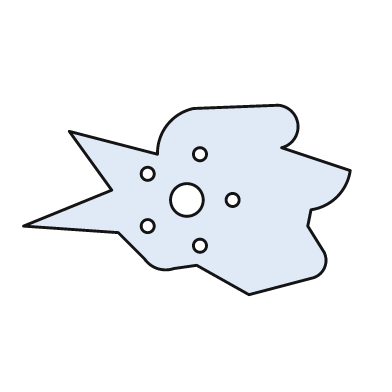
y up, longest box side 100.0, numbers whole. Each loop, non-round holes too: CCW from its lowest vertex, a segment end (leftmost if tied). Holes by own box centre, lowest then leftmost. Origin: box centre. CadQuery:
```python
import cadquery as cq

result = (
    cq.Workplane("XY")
    .moveTo(19.0, -29.0)
    .lineTo(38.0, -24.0)
    .threePointArc((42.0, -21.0), (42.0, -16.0))
    .lineTo(37.0, -8.0)
    .lineTo(38.0, -3.0)
    .threePointArc((46.0, 1.0), (50.0, 9.0))
    .lineTo(29.0, 16.0)
    .threePointArc((34.0, 23.0), (28.0, 29.0))
    .lineTo(2.0, 28.0)
    .threePointArc((-6.0, 23.0), (-9.0, 14.0))
    .lineTo(-36.0, 21.0)
    .lineTo(-23.0, 3.0)
    .lineTo(-50.0, -8.0)
    .lineTo(-21.0, -10.0)
    .lineTo(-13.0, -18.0)
    .threePointArc((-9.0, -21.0), (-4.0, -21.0))
    .lineTo(3.0, -20.0)
    .close()
    .moveTo(4.0, -14.0)
    .circle(2.0)
    .moveTo(-12.0, -8.0)
    .circle(2.0)
    .moveTo(0.0, 0.0)
    .circle(5.0)
    .moveTo(14.0, 0.0)
    .circle(2.0)
    .moveTo(-12.0, 8.0)
    .circle(2.0)
    .moveTo(4.0, 14.0)
    .circle(2.0)
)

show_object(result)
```